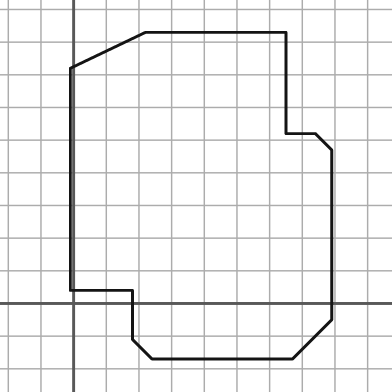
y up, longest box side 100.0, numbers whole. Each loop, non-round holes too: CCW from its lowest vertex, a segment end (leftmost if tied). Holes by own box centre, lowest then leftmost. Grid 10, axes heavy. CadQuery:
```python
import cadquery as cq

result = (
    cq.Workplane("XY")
    .moveTo(24.0, -17.0)
    .lineTo(67.0, -17.0)
    .lineTo(79.0, -5.0)
    .lineTo(79.0, 47.0)
    .lineTo(74.0, 52.0)
    .lineTo(65.0, 52.0)
    .lineTo(65.0, 83.0)
    .lineTo(22.0, 83.0)
    .lineTo(-1.0, 72.0)
    .lineTo(-1.0, 4.0)
    .lineTo(18.0, 4.0)
    .lineTo(18.0, -11.0)
    .close()
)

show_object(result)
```